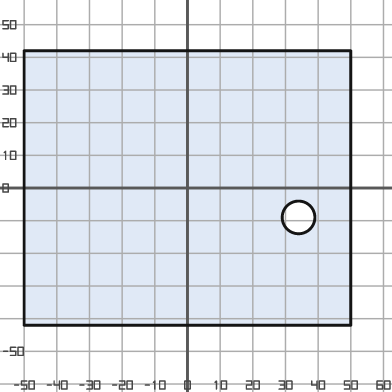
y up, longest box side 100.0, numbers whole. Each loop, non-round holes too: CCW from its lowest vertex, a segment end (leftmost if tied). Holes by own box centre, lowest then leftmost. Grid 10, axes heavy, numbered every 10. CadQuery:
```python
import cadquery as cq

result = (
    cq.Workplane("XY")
    .moveTo(-50.0, -42.0)
    .lineTo(50.0, -42.0)
    .lineTo(50.0, 42.0)
    .lineTo(-50.0, 42.0)
    .close()
    .moveTo(34.0, -9.0)
    .circle(5.0)
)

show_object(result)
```